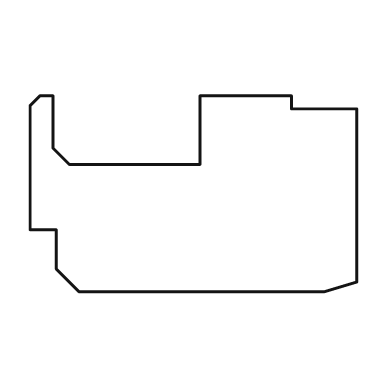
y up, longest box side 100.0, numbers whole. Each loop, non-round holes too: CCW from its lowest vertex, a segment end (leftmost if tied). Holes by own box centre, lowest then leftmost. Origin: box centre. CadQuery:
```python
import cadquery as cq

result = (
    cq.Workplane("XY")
    .moveTo(-35.0, -30.0)
    .lineTo(40.0, -30.0)
    .lineTo(50.0, -27.0)
    .lineTo(50.0, 26.0)
    .lineTo(30.0, 26.0)
    .lineTo(30.0, 30.0)
    .lineTo(2.0, 30.0)
    .lineTo(2.0, 9.0)
    .lineTo(-38.0, 9.0)
    .lineTo(-43.0, 14.0)
    .lineTo(-43.0, 30.0)
    .lineTo(-47.0, 30.0)
    .lineTo(-50.0, 27.0)
    .lineTo(-50.0, -11.0)
    .lineTo(-42.0, -11.0)
    .lineTo(-42.0, -23.0)
    .close()
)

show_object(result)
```